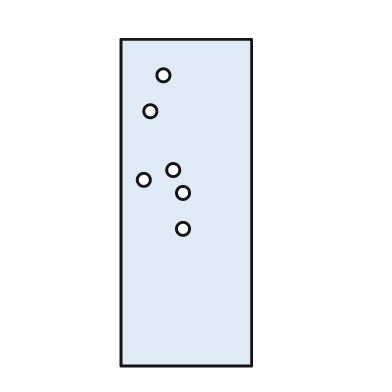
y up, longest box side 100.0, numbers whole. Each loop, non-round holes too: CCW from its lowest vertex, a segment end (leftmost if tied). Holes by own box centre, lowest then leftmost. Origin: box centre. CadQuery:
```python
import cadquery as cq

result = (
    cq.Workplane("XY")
    .moveTo(-20.0, -50.0)
    .lineTo(20.0, -50.0)
    .lineTo(20.0, 50.0)
    .lineTo(-20.0, 50.0)
    .close()
    .moveTo(-1.0, -8.0)
    .circle(2.0)
    .moveTo(-1.0, 3.0)
    .circle(2.0)
    .moveTo(-13.0, 7.0)
    .circle(2.0)
    .moveTo(-4.0, 10.0)
    .circle(2.0)
    .moveTo(-11.0, 28.0)
    .circle(2.0)
    .moveTo(-7.0, 39.0)
    .circle(2.0)
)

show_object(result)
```